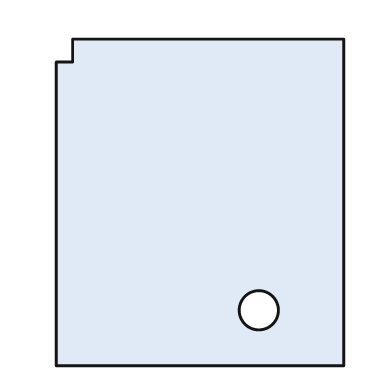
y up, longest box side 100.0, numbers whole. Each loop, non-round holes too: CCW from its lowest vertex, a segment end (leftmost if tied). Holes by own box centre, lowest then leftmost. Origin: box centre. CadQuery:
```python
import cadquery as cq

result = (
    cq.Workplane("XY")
    .moveTo(-44.0, -50.0)
    .lineTo(44.0, -50.0)
    .lineTo(44.0, 50.0)
    .lineTo(-39.0, 50.0)
    .lineTo(-39.0, 43.0)
    .lineTo(-44.0, 43.0)
    .close()
    .moveTo(18.0, -33.0)
    .circle(6.0)
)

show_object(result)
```